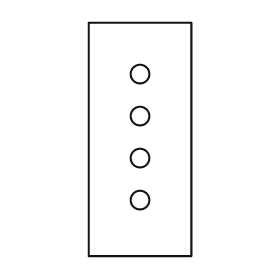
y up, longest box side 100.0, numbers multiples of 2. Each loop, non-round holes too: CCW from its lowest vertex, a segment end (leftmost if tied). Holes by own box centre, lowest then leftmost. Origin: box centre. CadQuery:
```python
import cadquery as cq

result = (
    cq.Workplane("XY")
    .moveTo(-22.0, -50.0)
    .lineTo(22.0, -50.0)
    .lineTo(22.0, 50.0)
    .lineTo(-22.0, 50.0)
    .close()
    .moveTo(0.0, -26.0)
    .circle(4.0)
    .moveTo(0.0, -8.0)
    .circle(4.0)
    .moveTo(0.0, 10.0)
    .circle(4.0)
    .moveTo(0.0, 28.0)
    .circle(4.0)
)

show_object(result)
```